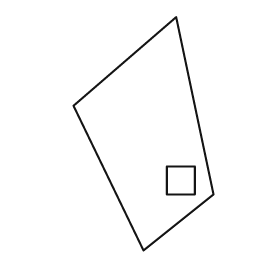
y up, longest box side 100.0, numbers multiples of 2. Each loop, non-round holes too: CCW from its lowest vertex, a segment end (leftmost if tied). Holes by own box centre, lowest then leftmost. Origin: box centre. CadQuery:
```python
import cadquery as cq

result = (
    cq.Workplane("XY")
    .moveTo(0.0, -50.0)
    .lineTo(30.0, -26.0)
    .lineTo(14.0, 50.0)
    .lineTo(-30.0, 12.0)
    .close()
    .moveTo(10.0, -26.0)
    .lineTo(22.0, -26.0)
    .lineTo(22.0, -14.0)
    .lineTo(10.0, -14.0)
    .close()
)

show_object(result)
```